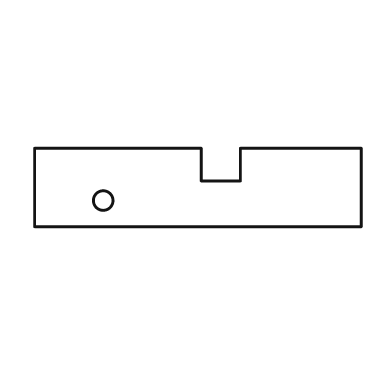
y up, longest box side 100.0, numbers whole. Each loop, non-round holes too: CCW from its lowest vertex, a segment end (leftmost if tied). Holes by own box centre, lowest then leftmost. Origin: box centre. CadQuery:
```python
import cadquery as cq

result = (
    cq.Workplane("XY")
    .moveTo(-50.0, -12.0)
    .lineTo(50.0, -12.0)
    .lineTo(50.0, 12.0)
    .lineTo(13.0, 12.0)
    .lineTo(13.0, 2.0)
    .lineTo(1.0, 2.0)
    .lineTo(1.0, 12.0)
    .lineTo(-50.0, 12.0)
    .close()
    .moveTo(-29.0, -4.0)
    .circle(3.0)
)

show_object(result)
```